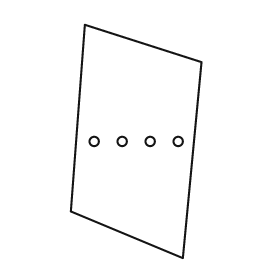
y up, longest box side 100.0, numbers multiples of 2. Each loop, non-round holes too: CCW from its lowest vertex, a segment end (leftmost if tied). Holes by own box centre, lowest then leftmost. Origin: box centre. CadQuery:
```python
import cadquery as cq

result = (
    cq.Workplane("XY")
    .moveTo(20.0, -50.0)
    .lineTo(28.0, 34.0)
    .lineTo(-22.0, 50.0)
    .lineTo(-28.0, -30.0)
    .close()
    .moveTo(-18.0, 0.0)
    .circle(2.0)
    .moveTo(-6.0, 0.0)
    .circle(2.0)
    .moveTo(6.0, 0.0)
    .circle(2.0)
    .moveTo(18.0, 0.0)
    .circle(2.0)
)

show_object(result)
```